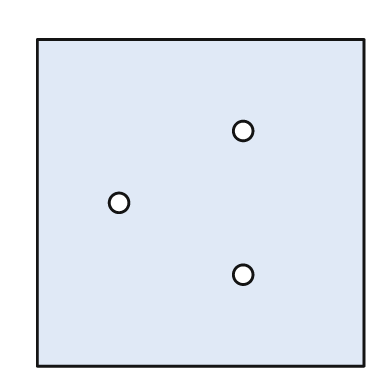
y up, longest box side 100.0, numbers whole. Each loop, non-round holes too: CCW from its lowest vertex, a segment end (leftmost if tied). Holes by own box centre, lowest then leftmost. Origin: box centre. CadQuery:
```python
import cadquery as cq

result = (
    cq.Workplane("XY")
    .moveTo(-50.0, -50.0)
    .lineTo(50.0, -50.0)
    .lineTo(50.0, 50.0)
    .lineTo(-50.0, 50.0)
    .close()
    .moveTo(13.0, -22.0)
    .circle(3.0)
    .moveTo(-25.0, 0.0)
    .circle(3.0)
    .moveTo(13.0, 22.0)
    .circle(3.0)
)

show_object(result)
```